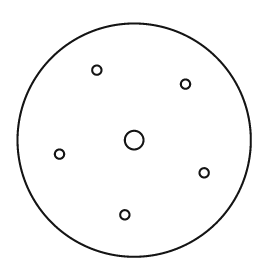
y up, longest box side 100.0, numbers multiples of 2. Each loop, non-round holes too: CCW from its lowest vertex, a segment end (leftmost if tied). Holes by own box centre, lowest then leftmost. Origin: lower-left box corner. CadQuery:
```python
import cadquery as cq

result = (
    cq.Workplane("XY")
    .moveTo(50.0, 50.0)
    .circle(50.0)
    .moveTo(46.0, 18.0)
    .circle(2.0)
    .moveTo(80.0, 36.0)
    .circle(2.0)
    .moveTo(18.0, 44.0)
    .circle(2.0)
    .moveTo(50.0, 50.0)
    .circle(4.0)
    .moveTo(72.0, 74.0)
    .circle(2.0)
    .moveTo(34.0, 80.0)
    .circle(2.0)
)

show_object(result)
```